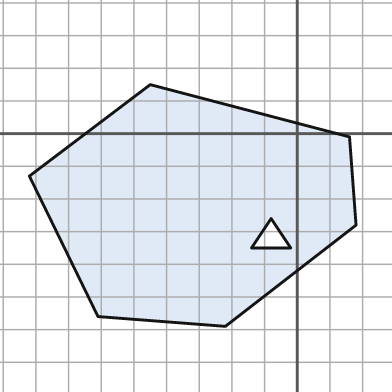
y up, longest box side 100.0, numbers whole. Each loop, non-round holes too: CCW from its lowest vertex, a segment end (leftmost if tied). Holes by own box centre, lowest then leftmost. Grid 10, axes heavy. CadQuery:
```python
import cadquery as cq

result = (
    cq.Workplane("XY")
    .moveTo(-22.0, -59.0)
    .lineTo(18.0, -28.0)
    .lineTo(16.0, -1.0)
    .lineTo(-45.0, 15.0)
    .lineTo(-82.0, -13.0)
    .lineTo(-61.0, -56.0)
    .close()
    .moveTo(-14.0, -35.0)
    .lineTo(-2.0, -35.0)
    .lineTo(-8.0, -26.0)
    .close()
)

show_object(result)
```